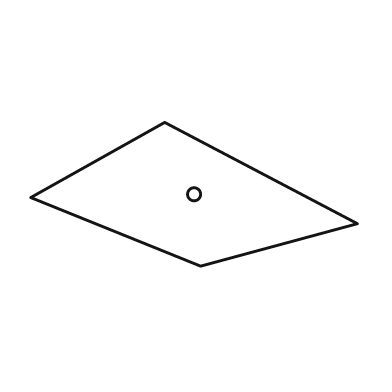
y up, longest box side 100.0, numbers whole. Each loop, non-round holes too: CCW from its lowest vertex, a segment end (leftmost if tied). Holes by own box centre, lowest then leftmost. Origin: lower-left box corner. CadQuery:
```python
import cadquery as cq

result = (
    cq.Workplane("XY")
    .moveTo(52.0, 0.0)
    .lineTo(100.0, 13.0)
    .lineTo(41.0, 44.0)
    .lineTo(0.0, 21.0)
    .close()
    .moveTo(50.0, 22.0)
    .circle(2.0)
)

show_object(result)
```